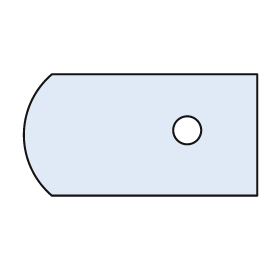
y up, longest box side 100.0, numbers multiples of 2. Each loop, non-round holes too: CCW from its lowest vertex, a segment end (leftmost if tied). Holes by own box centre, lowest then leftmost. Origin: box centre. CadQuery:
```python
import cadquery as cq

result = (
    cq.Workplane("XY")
    .moveTo(-38.0, -26.0)
    .lineTo(50.0, -26.0)
    .lineTo(50.0, 26.0)
    .lineTo(-38.0, 26.0)
    .threePointArc((-50.0, 0.0), (-38.0, -26.0))
    .close()
    .moveTo(20.0, 2.0)
    .circle(6.0)
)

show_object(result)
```